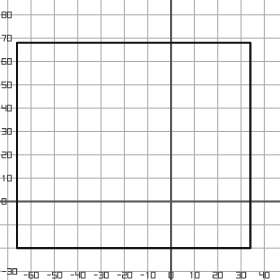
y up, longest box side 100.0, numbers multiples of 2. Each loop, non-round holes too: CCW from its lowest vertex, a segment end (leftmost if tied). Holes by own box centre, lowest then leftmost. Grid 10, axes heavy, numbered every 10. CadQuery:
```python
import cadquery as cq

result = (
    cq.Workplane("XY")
    .moveTo(-66.0, -20.0)
    .lineTo(34.0, -20.0)
    .lineTo(34.0, 68.0)
    .lineTo(-66.0, 68.0)
    .close()
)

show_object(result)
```